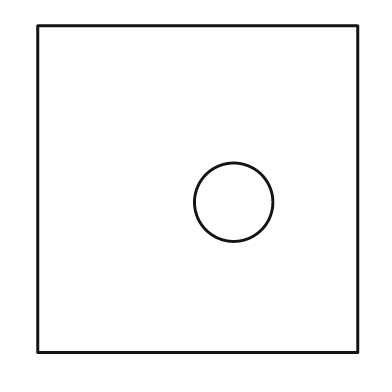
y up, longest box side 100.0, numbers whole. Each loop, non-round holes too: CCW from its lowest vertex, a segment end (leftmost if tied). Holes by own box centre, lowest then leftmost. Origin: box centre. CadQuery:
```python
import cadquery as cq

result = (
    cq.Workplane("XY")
    .moveTo(-49.0, -50.0)
    .lineTo(49.0, -50.0)
    .lineTo(49.0, 50.0)
    .lineTo(-49.0, 50.0)
    .close()
    .moveTo(11.0, -4.0)
    .circle(12.0)
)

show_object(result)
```